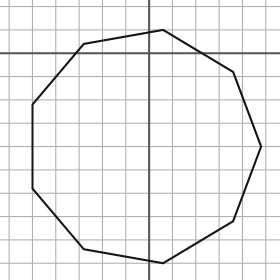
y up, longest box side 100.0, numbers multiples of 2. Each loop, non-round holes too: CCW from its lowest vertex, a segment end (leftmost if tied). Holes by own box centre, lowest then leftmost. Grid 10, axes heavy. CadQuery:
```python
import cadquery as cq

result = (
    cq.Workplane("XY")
    .moveTo(6.0, -90.0)
    .lineTo(36.0, -72.0)
    .lineTo(48.0, -40.0)
    .lineTo(36.0, -8.0)
    .lineTo(6.0, 10.0)
    .lineTo(-28.0, 4.0)
    .lineTo(-50.0, -22.0)
    .lineTo(-50.0, -58.0)
    .lineTo(-28.0, -84.0)
    .close()
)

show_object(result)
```